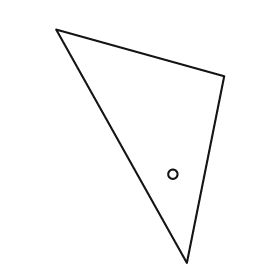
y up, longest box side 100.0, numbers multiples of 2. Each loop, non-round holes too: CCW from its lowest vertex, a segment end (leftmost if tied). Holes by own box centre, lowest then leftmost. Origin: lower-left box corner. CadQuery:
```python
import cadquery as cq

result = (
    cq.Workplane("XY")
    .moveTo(56.0, 0.0)
    .lineTo(72.0, 80.0)
    .lineTo(0.0, 100.0)
    .close()
    .moveTo(50.0, 38.0)
    .circle(2.0)
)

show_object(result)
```